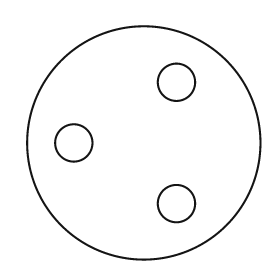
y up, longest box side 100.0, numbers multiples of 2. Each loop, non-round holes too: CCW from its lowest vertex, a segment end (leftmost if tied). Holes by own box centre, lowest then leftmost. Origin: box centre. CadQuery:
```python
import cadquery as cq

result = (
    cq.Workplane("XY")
    .moveTo(0.0, 0.0)
    .circle(50.0)
    .moveTo(14.0, -26.0)
    .circle(8.0)
    .moveTo(-30.0, 0.0)
    .circle(8.0)
    .moveTo(14.0, 26.0)
    .circle(8.0)
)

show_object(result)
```